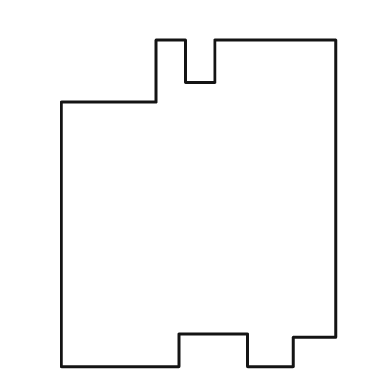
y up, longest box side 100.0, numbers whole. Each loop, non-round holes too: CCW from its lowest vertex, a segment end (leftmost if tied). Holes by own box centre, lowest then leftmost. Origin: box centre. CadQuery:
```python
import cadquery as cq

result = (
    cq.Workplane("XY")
    .moveTo(-42.0, -50.0)
    .lineTo(-6.0, -50.0)
    .lineTo(-6.0, -40.0)
    .lineTo(15.0, -40.0)
    .lineTo(15.0, -50.0)
    .lineTo(29.0, -50.0)
    .lineTo(29.0, -41.0)
    .lineTo(42.0, -41.0)
    .lineTo(42.0, 50.0)
    .lineTo(5.0, 50.0)
    .lineTo(5.0, 37.0)
    .lineTo(-4.0, 37.0)
    .lineTo(-4.0, 50.0)
    .lineTo(-13.0, 50.0)
    .lineTo(-13.0, 31.0)
    .lineTo(-42.0, 31.0)
    .close()
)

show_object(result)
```